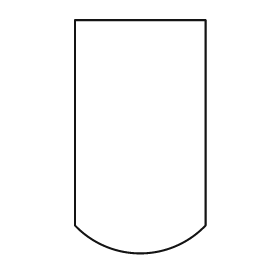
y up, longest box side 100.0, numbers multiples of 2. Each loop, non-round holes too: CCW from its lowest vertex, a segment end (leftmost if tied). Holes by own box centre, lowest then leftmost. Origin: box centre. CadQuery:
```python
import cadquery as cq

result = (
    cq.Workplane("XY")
    .moveTo(-28.0, -38.0)
    .threePointArc((0.0, -50.0), (28.0, -38.0))
    .lineTo(28.0, 50.0)
    .lineTo(-28.0, 50.0)
    .close()
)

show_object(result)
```